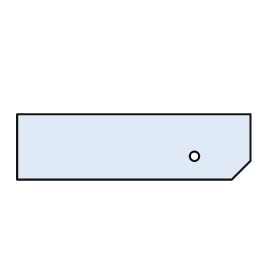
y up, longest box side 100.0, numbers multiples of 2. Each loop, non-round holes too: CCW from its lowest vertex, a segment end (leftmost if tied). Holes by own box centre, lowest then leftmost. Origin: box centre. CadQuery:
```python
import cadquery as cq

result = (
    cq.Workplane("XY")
    .moveTo(-50.0, -14.0)
    .lineTo(42.0, -14.0)
    .lineTo(50.0, -6.0)
    .lineTo(50.0, 14.0)
    .lineTo(-50.0, 14.0)
    .close()
    .moveTo(26.0, -4.0)
    .circle(2.0)
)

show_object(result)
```